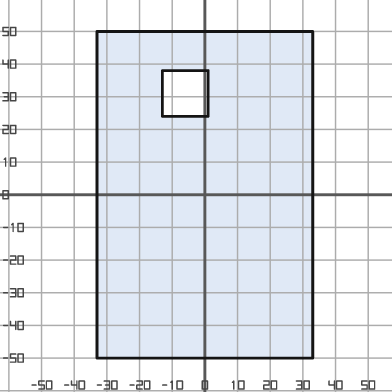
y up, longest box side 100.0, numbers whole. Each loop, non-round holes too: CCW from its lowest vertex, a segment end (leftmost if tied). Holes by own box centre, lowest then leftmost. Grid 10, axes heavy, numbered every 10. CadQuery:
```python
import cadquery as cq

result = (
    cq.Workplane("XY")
    .moveTo(-33.0, -50.0)
    .lineTo(33.0, -50.0)
    .lineTo(33.0, 50.0)
    .lineTo(-33.0, 50.0)
    .close()
    .moveTo(-13.0, 24.0)
    .lineTo(1.0, 24.0)
    .lineTo(1.0, 38.0)
    .lineTo(-13.0, 38.0)
    .close()
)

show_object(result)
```